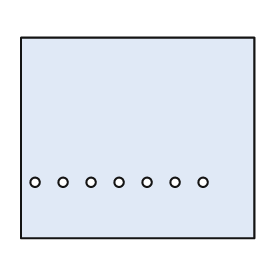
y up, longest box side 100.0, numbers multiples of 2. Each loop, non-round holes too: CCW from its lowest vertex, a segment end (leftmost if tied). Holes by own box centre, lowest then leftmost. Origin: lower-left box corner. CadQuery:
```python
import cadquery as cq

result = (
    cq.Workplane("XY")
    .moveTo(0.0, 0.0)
    .lineTo(100.0, 0.0)
    .lineTo(100.0, 86.0)
    .lineTo(0.0, 86.0)
    .close()
    .moveTo(6.0, 24.0)
    .circle(2.0)
    .moveTo(18.0, 24.0)
    .circle(2.0)
    .moveTo(30.0, 24.0)
    .circle(2.0)
    .moveTo(42.0, 24.0)
    .circle(2.0)
    .moveTo(54.0, 24.0)
    .circle(2.0)
    .moveTo(66.0, 24.0)
    .circle(2.0)
    .moveTo(78.0, 24.0)
    .circle(2.0)
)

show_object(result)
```